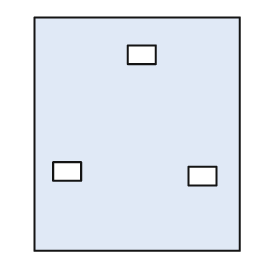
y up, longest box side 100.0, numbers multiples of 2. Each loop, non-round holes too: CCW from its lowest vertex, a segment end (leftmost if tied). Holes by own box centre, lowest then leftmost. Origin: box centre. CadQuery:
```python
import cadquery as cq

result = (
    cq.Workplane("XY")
    .moveTo(-44.0, -50.0)
    .lineTo(44.0, -50.0)
    .lineTo(44.0, 50.0)
    .lineTo(-44.0, 50.0)
    .close()
    .moveTo(22.0, -22.0)
    .lineTo(34.0, -22.0)
    .lineTo(34.0, -14.0)
    .lineTo(22.0, -14.0)
    .close()
    .moveTo(-36.0, -20.0)
    .lineTo(-24.0, -20.0)
    .lineTo(-24.0, -12.0)
    .lineTo(-36.0, -12.0)
    .close()
    .moveTo(-4.0, 30.0)
    .lineTo(8.0, 30.0)
    .lineTo(8.0, 38.0)
    .lineTo(-4.0, 38.0)
    .close()
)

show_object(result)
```